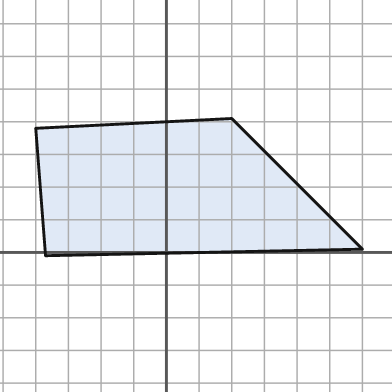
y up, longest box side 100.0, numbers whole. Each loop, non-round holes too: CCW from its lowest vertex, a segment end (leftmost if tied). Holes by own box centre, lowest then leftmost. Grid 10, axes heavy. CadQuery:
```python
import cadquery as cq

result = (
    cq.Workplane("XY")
    .moveTo(-37.0, -1.0)
    .lineTo(60.0, 1.0)
    .lineTo(20.0, 41.0)
    .lineTo(-40.0, 38.0)
    .close()
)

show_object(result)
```